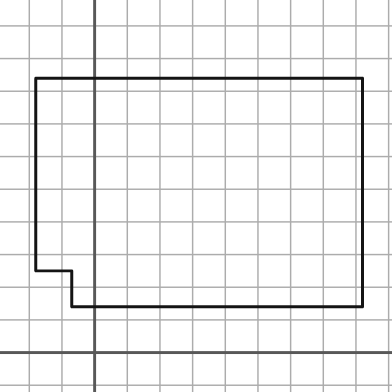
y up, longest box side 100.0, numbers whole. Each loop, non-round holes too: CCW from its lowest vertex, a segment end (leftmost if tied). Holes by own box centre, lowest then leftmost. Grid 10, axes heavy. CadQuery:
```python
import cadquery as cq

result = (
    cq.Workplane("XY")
    .moveTo(-7.0, 14.0)
    .lineTo(82.0, 14.0)
    .lineTo(82.0, 84.0)
    .lineTo(-18.0, 84.0)
    .lineTo(-18.0, 25.0)
    .lineTo(-7.0, 25.0)
    .close()
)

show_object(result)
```